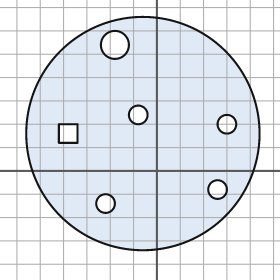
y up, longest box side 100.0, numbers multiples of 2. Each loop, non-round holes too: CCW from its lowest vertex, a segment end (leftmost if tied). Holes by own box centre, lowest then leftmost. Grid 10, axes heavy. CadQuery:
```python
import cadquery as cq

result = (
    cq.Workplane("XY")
    .moveTo(-6.0, 16.0)
    .circle(50.0)
    .moveTo(-22.0, -14.0)
    .circle(4.0)
    .moveTo(26.0, -8.0)
    .circle(4.0)
    .moveTo(-42.0, 12.0)
    .lineTo(-34.0, 12.0)
    .lineTo(-34.0, 20.0)
    .lineTo(-42.0, 20.0)
    .close()
    .moveTo(30.0, 20.0)
    .circle(4.0)
    .moveTo(-8.0, 24.0)
    .circle(4.0)
    .moveTo(-18.0, 54.0)
    .circle(6.0)
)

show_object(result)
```